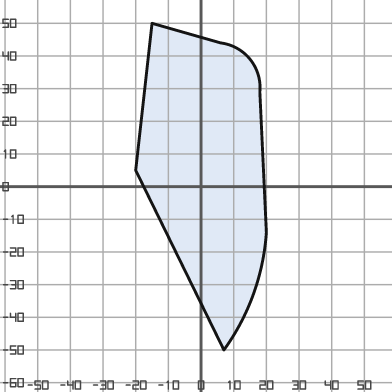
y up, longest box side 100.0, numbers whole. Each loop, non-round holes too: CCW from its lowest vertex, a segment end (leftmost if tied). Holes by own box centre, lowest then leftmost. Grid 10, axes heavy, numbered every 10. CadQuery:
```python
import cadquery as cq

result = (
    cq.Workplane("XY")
    .moveTo(7.0, -50.0)
    .threePointArc((16.0, -33.0), (20.0, -14.0))
    .lineTo(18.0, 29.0)
    .threePointArc((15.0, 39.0), (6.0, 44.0))
    .lineTo(-15.0, 50.0)
    .lineTo(-20.0, 5.0)
    .close()
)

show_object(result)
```